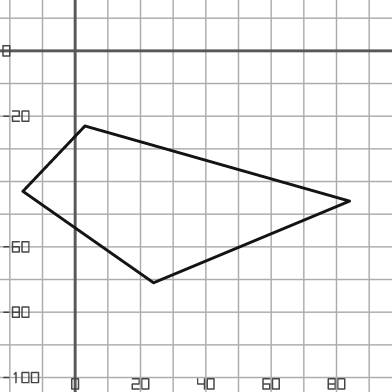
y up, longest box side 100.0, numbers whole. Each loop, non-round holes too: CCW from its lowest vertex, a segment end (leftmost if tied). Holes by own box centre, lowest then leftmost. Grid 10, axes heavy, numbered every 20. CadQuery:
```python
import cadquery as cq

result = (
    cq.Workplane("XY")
    .moveTo(24.0, -71.0)
    .lineTo(84.0, -46.0)
    .lineTo(3.0, -23.0)
    .lineTo(-16.0, -43.0)
    .close()
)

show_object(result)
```